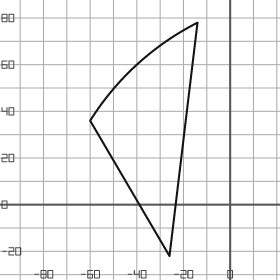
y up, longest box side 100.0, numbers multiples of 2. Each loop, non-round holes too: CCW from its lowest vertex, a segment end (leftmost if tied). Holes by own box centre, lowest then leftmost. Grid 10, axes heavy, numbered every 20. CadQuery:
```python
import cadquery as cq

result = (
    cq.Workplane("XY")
    .moveTo(-26.0, -22.0)
    .lineTo(-14.0, 78.0)
    .threePointArc((-40.0, 60.0), (-60.0, 36.0))
    .close()
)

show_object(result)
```